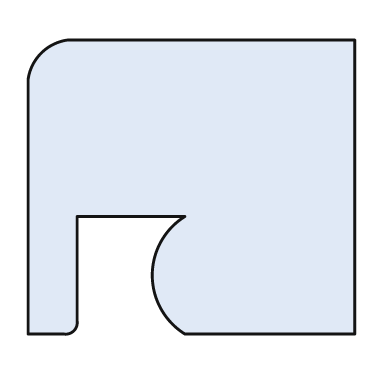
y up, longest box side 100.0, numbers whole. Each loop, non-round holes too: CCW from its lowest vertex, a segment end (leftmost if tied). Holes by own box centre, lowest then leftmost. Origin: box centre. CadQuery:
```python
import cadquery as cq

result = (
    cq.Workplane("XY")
    .moveTo(-50.0, -45.0)
    .lineTo(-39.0, -45.0)
    .threePointArc((-36.0, -44.0), (-35.0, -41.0))
    .lineTo(-35.0, -9.0)
    .lineTo(-2.0, -9.0)
    .threePointArc((-12.0, -27.0), (-2.0, -45.0))
    .lineTo(50.0, -45.0)
    .lineTo(50.0, 45.0)
    .lineTo(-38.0, 45.0)
    .threePointArc((-46.0, 41.0), (-50.0, 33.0))
    .close()
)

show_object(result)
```